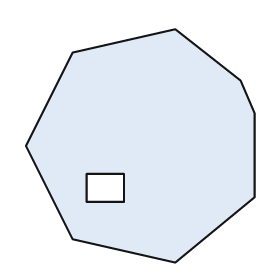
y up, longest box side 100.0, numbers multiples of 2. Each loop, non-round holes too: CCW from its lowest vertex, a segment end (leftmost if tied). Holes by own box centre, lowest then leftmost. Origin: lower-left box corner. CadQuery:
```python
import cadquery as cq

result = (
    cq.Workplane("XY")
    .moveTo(64.0, 0.0)
    .lineTo(98.0, 28.0)
    .lineTo(98.0, 64.0)
    .lineTo(92.0, 78.0)
    .lineTo(64.0, 100.0)
    .lineTo(20.0, 90.0)
    .lineTo(0.0, 50.0)
    .lineTo(20.0, 10.0)
    .close()
    .moveTo(26.0, 26.0)
    .lineTo(42.0, 26.0)
    .lineTo(42.0, 38.0)
    .lineTo(26.0, 38.0)
    .close()
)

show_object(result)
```